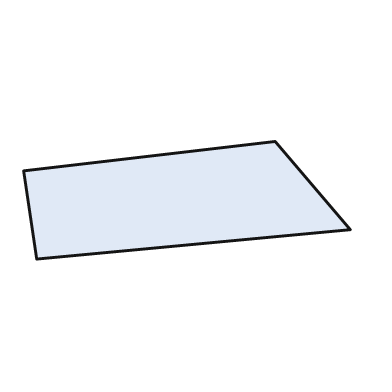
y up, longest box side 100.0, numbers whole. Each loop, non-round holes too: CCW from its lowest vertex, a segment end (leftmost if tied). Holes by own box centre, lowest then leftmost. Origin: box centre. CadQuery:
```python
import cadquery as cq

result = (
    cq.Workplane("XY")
    .moveTo(-46.0, -18.0)
    .lineTo(50.0, -9.0)
    .lineTo(27.0, 18.0)
    .lineTo(-50.0, 9.0)
    .close()
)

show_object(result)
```